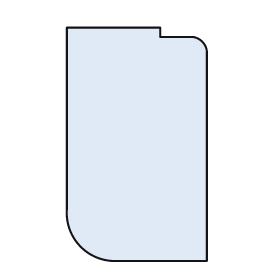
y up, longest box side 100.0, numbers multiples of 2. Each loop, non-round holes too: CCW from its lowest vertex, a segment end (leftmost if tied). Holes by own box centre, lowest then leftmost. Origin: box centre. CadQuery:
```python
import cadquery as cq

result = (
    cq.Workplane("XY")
    .moveTo(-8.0, -50.0)
    .lineTo(30.0, -50.0)
    .lineTo(30.0, 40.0)
    .threePointArc((28.0, 44.0), (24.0, 46.0))
    .lineTo(10.0, 46.0)
    .lineTo(10.0, 50.0)
    .lineTo(-30.0, 50.0)
    .lineTo(-30.0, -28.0)
    .threePointArc((-24.0, -44.0), (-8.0, -50.0))
    .close()
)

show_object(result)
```